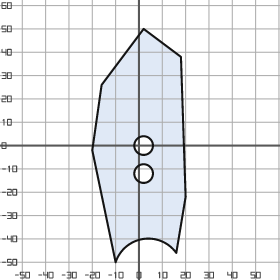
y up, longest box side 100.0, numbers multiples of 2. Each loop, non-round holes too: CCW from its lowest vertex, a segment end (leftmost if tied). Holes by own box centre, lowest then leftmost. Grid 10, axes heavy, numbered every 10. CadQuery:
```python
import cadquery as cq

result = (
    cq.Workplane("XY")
    .moveTo(-10.0, -50.0)
    .threePointArc((2.0, -40.0), (16.0, -46.0))
    .lineTo(20.0, -22.0)
    .lineTo(18.0, 38.0)
    .lineTo(2.0, 50.0)
    .lineTo(-16.0, 26.0)
    .lineTo(-20.0, -2.0)
    .close()
    .moveTo(2.0, -12.0)
    .circle(4.0)
    .moveTo(2.0, 0.0)
    .circle(4.0)
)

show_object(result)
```